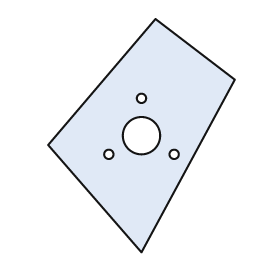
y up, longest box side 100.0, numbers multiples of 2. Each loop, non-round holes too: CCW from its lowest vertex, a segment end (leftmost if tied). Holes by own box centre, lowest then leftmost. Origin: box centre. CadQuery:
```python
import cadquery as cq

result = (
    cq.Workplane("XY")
    .moveTo(0.0, -50.0)
    .lineTo(40.0, 24.0)
    .lineTo(6.0, 50.0)
    .lineTo(-40.0, -4.0)
    .close()
    .moveTo(-14.0, -8.0)
    .circle(2.0)
    .moveTo(14.0, -8.0)
    .circle(2.0)
    .moveTo(0.0, 0.0)
    .circle(8.0)
    .moveTo(0.0, 16.0)
    .circle(2.0)
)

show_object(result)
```